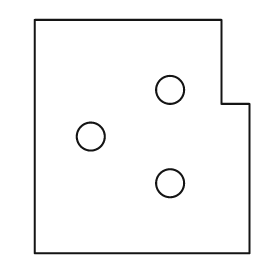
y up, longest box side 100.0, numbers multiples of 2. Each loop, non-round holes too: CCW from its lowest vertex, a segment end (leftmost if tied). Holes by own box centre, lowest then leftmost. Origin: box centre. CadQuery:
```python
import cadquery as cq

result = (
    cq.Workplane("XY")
    .moveTo(-46.0, -50.0)
    .lineTo(46.0, -50.0)
    .lineTo(46.0, 14.0)
    .lineTo(34.0, 14.0)
    .lineTo(34.0, 50.0)
    .lineTo(-46.0, 50.0)
    .close()
    .moveTo(12.0, -20.0)
    .circle(6.0)
    .moveTo(-22.0, 0.0)
    .circle(6.0)
    .moveTo(12.0, 20.0)
    .circle(6.0)
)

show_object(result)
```